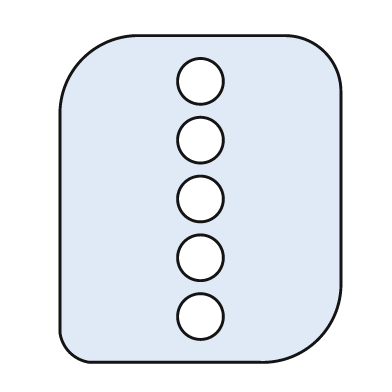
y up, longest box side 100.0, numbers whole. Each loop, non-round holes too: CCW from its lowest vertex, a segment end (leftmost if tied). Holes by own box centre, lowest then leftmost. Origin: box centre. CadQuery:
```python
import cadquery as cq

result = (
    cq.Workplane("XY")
    .moveTo(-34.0, -50.0)
    .lineTo(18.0, -50.0)
    .threePointArc((36.0, -43.0), (43.0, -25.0))
    .lineTo(43.0, 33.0)
    .threePointArc((38.0, 45.0), (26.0, 50.0))
    .lineTo(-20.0, 50.0)
    .threePointArc((-36.0, 43.0), (-43.0, 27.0))
    .lineTo(-43.0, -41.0)
    .threePointArc((-40.0, -47.0), (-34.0, -50.0))
    .close()
    .moveTo(0.0, -36.0)
    .circle(7.0)
    .moveTo(0.0, -18.0)
    .circle(7.0)
    .moveTo(0.0, 0.0)
    .circle(7.0)
    .moveTo(0.0, 18.0)
    .circle(7.0)
    .moveTo(0.0, 36.0)
    .circle(7.0)
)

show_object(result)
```